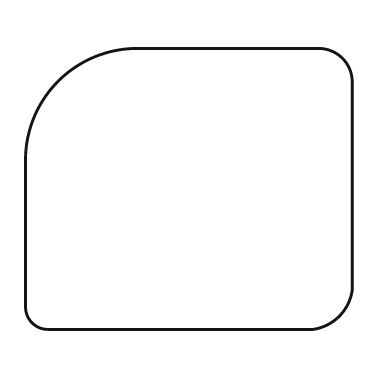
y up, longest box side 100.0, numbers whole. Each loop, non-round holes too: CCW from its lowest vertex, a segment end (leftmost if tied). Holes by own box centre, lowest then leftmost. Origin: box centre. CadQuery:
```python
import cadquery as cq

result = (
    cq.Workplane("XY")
    .moveTo(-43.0, -43.0)
    .lineTo(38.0, -43.0)
    .threePointArc((46.0, -39.0), (50.0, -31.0))
    .lineTo(50.0, 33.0)
    .threePointArc((47.0, 40.0), (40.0, 43.0))
    .lineTo(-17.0, 43.0)
    .threePointArc((-40.0, 33.0), (-50.0, 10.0))
    .lineTo(-50.0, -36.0)
    .threePointArc((-48.0, -41.0), (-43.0, -43.0))
    .close()
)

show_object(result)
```